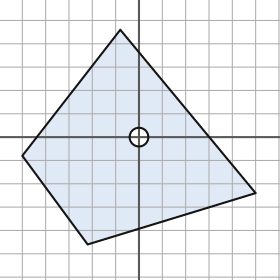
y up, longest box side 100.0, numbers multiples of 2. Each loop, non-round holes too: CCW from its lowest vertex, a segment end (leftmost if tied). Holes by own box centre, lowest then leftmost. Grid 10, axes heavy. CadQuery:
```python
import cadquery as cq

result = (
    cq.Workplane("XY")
    .moveTo(-22.0, -46.0)
    .lineTo(50.0, -24.0)
    .lineTo(-8.0, 46.0)
    .lineTo(-50.0, -8.0)
    .close()
    .moveTo(0.0, 0.0)
    .circle(4.0)
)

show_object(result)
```